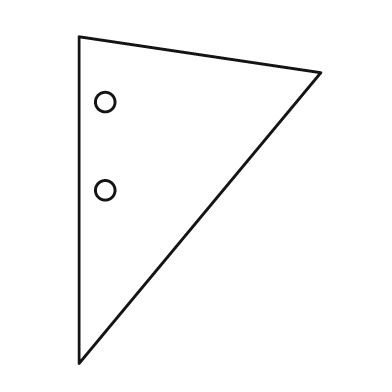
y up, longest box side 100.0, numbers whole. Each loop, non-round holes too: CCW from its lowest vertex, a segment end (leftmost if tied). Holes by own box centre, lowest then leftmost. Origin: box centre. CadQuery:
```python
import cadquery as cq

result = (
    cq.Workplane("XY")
    .moveTo(-37.0, -50.0)
    .lineTo(37.0, 39.0)
    .lineTo(-37.0, 50.0)
    .close()
    .moveTo(-29.0, 3.0)
    .circle(3.0)
    .moveTo(-29.0, 30.0)
    .circle(3.0)
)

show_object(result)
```